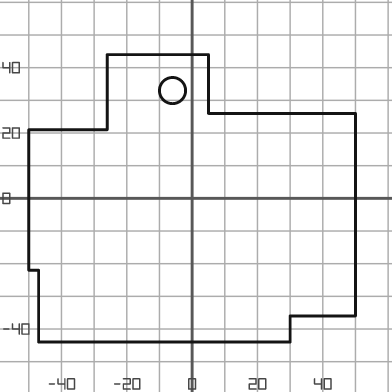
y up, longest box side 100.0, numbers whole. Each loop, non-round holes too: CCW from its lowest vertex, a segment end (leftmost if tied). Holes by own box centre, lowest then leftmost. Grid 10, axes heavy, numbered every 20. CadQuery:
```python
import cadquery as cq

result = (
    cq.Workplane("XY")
    .moveTo(-47.0, -44.0)
    .lineTo(30.0, -44.0)
    .lineTo(30.0, -36.0)
    .lineTo(50.0, -36.0)
    .lineTo(50.0, 26.0)
    .lineTo(5.0, 26.0)
    .lineTo(5.0, 44.0)
    .lineTo(-26.0, 44.0)
    .lineTo(-26.0, 21.0)
    .lineTo(-50.0, 21.0)
    .lineTo(-50.0, -22.0)
    .lineTo(-47.0, -22.0)
    .close()
    .moveTo(-6.0, 33.0)
    .circle(4.0)
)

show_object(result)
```